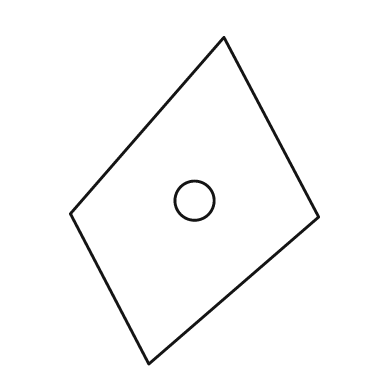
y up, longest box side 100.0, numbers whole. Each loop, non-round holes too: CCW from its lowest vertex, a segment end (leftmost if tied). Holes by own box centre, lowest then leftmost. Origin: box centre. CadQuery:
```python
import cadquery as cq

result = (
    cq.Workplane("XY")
    .moveTo(-14.0, -50.0)
    .lineTo(38.0, -5.0)
    .lineTo(9.0, 50.0)
    .lineTo(-38.0, -4.0)
    .close()
    .moveTo(0.0, 0.0)
    .circle(6.0)
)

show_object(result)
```